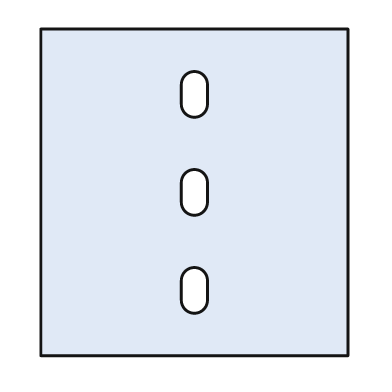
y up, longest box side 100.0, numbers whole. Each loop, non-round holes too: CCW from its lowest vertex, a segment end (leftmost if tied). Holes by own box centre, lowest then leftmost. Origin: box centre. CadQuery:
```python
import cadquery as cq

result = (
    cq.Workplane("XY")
    .moveTo(-47.0, -50.0)
    .lineTo(47.0, -50.0)
    .lineTo(47.0, 50.0)
    .lineTo(-47.0, 50.0)
    .close()
    .moveTo(-4.0, -33.0)
    .threePointArc((0.0, -37.0), (4.0, -33.0))
    .lineTo(4.0, -27.0)
    .threePointArc((0.0, -23.0), (-4.0, -27.0))
    .close()
    .moveTo(-4.0, -3.0)
    .threePointArc((0.0, -7.0), (4.0, -3.0))
    .lineTo(4.0, 3.0)
    .threePointArc((0.0, 7.0), (-4.0, 3.0))
    .close()
    .moveTo(-4.0, 27.0)
    .threePointArc((0.0, 23.0), (4.0, 27.0))
    .lineTo(4.0, 33.0)
    .threePointArc((0.0, 37.0), (-4.0, 33.0))
    .close()
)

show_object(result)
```